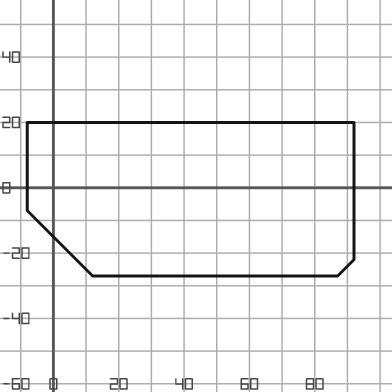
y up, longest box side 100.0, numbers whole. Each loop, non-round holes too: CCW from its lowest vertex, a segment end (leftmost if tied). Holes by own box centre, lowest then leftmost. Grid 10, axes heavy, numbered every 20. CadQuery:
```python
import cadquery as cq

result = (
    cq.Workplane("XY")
    .moveTo(12.0, -27.0)
    .lineTo(87.0, -27.0)
    .lineTo(92.0, -22.0)
    .lineTo(92.0, 20.0)
    .lineTo(-8.0, 20.0)
    .lineTo(-8.0, -7.0)
    .close()
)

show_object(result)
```